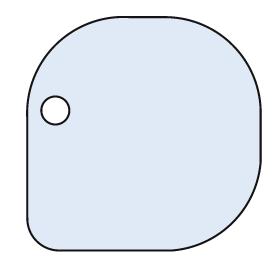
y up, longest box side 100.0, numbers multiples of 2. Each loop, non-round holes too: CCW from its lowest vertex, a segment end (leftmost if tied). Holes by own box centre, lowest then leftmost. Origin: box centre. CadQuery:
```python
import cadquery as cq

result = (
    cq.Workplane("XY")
    .moveTo(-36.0, -50.0)
    .lineTo(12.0, -50.0)
    .threePointArc((38.0, -38.0), (50.0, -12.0))
    .lineTo(50.0, 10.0)
    .threePointArc((38.0, 38.0), (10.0, 50.0))
    .lineTo(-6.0, 50.0)
    .threePointArc((-38.0, 38.0), (-50.0, 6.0))
    .lineTo(-50.0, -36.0)
    .threePointArc((-46.0, -46.0), (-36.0, -50.0))
    .close()
    .moveTo(-38.0, 10.0)
    .circle(6.0)
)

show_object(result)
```